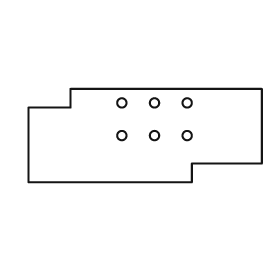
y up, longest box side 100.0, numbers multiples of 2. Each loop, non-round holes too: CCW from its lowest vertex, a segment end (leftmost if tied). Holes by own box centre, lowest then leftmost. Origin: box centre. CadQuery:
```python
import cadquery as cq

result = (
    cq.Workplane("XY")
    .moveTo(-50.0, -20.0)
    .lineTo(20.0, -20.0)
    .lineTo(20.0, -12.0)
    .lineTo(50.0, -12.0)
    .lineTo(50.0, 20.0)
    .lineTo(-32.0, 20.0)
    .lineTo(-32.0, 12.0)
    .lineTo(-50.0, 12.0)
    .close()
    .moveTo(-10.0, 0.0)
    .circle(2.0)
    .moveTo(4.0, 0.0)
    .circle(2.0)
    .moveTo(18.0, 0.0)
    .circle(2.0)
    .moveTo(-10.0, 14.0)
    .circle(2.0)
    .moveTo(4.0, 14.0)
    .circle(2.0)
    .moveTo(18.0, 14.0)
    .circle(2.0)
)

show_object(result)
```